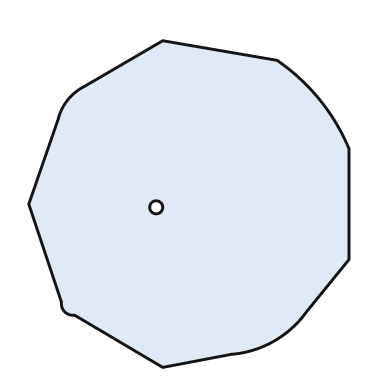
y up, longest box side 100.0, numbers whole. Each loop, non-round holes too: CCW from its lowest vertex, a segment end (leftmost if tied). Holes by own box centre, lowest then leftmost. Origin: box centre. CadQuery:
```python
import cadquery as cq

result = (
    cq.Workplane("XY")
    .moveTo(-8.0, -50.0)
    .lineTo(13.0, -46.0)
    .threePointArc((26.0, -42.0), (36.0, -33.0))
    .lineTo(49.0, -17.0)
    .lineTo(49.0, 17.0)
    .threePointArc((40.0, 32.0), (27.0, 44.0))
    .lineTo(-8.0, 50.0)
    .lineTo(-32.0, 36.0)
    .threePointArc((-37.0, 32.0), (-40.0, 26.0))
    .lineTo(-49.0, 0.0)
    .lineTo(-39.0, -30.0)
    .threePointArc((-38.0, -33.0), (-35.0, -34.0))
    .close()
    .moveTo(-10.0, -1.0)
    .circle(2.0)
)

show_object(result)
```